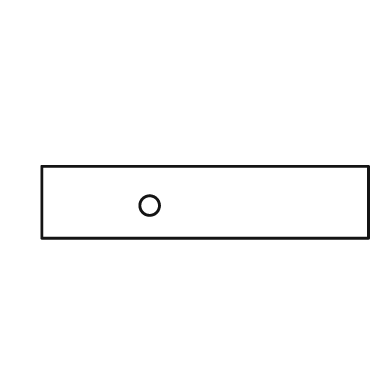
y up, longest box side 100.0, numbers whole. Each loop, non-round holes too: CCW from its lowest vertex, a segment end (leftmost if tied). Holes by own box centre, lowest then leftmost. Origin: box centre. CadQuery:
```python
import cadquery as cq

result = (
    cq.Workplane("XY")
    .moveTo(-50.0, -11.0)
    .lineTo(50.0, -11.0)
    .lineTo(50.0, 11.0)
    .lineTo(-50.0, 11.0)
    .close()
    .moveTo(-17.0, -1.0)
    .circle(3.0)
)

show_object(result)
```